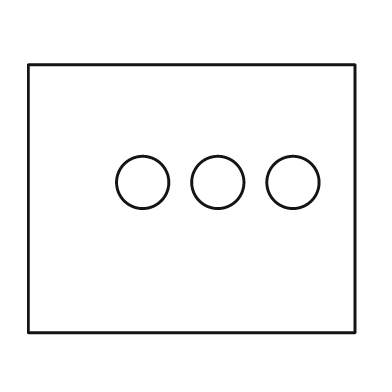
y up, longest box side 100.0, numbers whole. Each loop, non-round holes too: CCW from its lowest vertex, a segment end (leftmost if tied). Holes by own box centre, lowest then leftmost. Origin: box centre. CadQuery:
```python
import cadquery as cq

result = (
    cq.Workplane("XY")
    .moveTo(-50.0, -41.0)
    .lineTo(50.0, -41.0)
    .lineTo(50.0, 41.0)
    .lineTo(-50.0, 41.0)
    .close()
    .moveTo(-15.0, 5.0)
    .circle(8.0)
    .moveTo(8.0, 5.0)
    .circle(8.0)
    .moveTo(31.0, 5.0)
    .circle(8.0)
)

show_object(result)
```